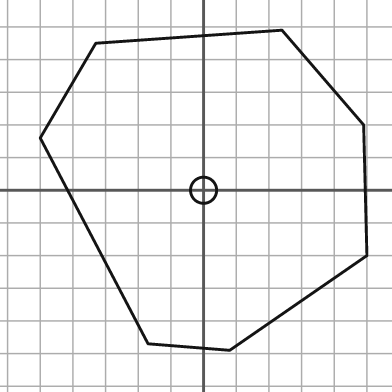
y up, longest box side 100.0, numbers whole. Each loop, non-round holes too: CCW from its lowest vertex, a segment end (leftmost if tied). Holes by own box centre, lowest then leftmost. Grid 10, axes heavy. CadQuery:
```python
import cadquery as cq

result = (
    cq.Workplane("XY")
    .moveTo(8.0, -49.0)
    .lineTo(50.0, -20.0)
    .lineTo(49.0, 20.0)
    .lineTo(24.0, 49.0)
    .lineTo(-33.0, 45.0)
    .lineTo(-50.0, 16.0)
    .lineTo(-17.0, -47.0)
    .close()
    .moveTo(0.0, 0.0)
    .circle(4.0)
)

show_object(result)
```